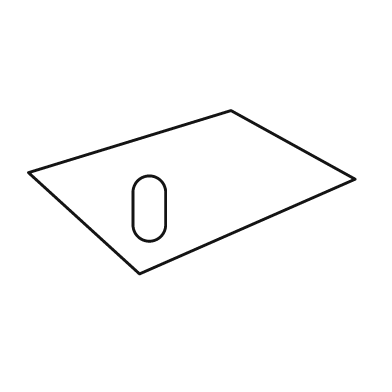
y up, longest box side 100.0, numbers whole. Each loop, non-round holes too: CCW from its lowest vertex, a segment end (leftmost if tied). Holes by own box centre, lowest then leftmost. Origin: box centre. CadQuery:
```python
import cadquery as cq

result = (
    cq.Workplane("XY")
    .moveTo(-16.0, -25.0)
    .lineTo(50.0, 4.0)
    .lineTo(12.0, 25.0)
    .lineTo(-50.0, 6.0)
    .close()
    .moveTo(-18.0, -10.0)
    .threePointArc((-13.0, -15.0), (-8.0, -10.0))
    .lineTo(-8.0, 0.0)
    .threePointArc((-13.0, 5.0), (-18.0, 0.0))
    .close()
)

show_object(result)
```